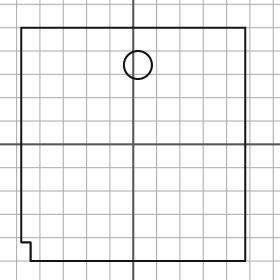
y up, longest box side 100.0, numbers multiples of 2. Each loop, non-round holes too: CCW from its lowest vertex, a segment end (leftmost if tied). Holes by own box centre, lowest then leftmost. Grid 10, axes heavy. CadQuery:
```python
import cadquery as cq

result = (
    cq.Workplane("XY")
    .moveTo(-44.0, -50.0)
    .lineTo(48.0, -50.0)
    .lineTo(48.0, 50.0)
    .lineTo(-48.0, 50.0)
    .lineTo(-48.0, -42.0)
    .lineTo(-44.0, -42.0)
    .close()
    .moveTo(2.0, 34.0)
    .circle(6.0)
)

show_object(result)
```